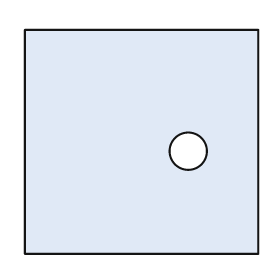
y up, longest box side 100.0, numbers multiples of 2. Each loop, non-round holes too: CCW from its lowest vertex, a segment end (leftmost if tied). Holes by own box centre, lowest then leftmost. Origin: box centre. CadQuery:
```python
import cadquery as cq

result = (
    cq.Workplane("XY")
    .moveTo(-50.0, -48.0)
    .lineTo(50.0, -48.0)
    .lineTo(50.0, 48.0)
    .lineTo(-50.0, 48.0)
    .close()
    .moveTo(20.0, -4.0)
    .circle(8.0)
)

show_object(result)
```